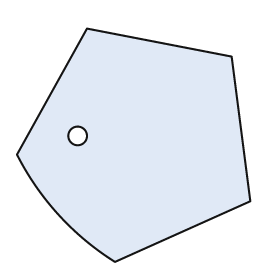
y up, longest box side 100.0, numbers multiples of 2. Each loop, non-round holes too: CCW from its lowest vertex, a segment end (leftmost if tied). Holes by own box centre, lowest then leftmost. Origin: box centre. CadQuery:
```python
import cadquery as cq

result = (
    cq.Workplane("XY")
    .moveTo(-8.0, -50.0)
    .lineTo(50.0, -24.0)
    .lineTo(42.0, 38.0)
    .lineTo(-20.0, 50.0)
    .lineTo(-50.0, -4.0)
    .threePointArc((-32.0, -30.0), (-8.0, -50.0))
    .close()
    .moveTo(-24.0, 4.0)
    .circle(4.0)
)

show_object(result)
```